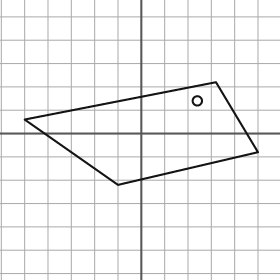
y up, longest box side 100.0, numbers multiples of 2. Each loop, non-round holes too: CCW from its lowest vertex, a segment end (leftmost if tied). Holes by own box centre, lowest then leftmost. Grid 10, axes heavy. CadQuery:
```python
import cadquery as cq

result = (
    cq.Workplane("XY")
    .moveTo(-10.0, -22.0)
    .lineTo(50.0, -8.0)
    .lineTo(32.0, 22.0)
    .lineTo(-50.0, 6.0)
    .close()
    .moveTo(24.0, 14.0)
    .circle(2.0)
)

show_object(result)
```